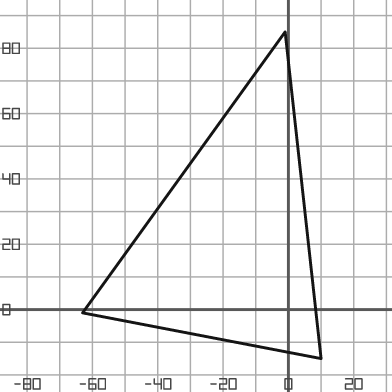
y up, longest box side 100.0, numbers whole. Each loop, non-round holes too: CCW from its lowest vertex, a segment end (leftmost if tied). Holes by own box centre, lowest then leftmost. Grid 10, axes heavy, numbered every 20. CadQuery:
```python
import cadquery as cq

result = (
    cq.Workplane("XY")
    .moveTo(10.0, -15.0)
    .lineTo(-1.0, 85.0)
    .lineTo(-63.0, -1.0)
    .close()
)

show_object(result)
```